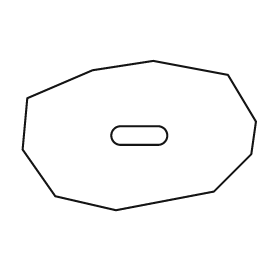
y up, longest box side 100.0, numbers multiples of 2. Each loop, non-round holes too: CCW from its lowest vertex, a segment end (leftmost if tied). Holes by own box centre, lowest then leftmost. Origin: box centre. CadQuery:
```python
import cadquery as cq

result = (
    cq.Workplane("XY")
    .moveTo(-10.0, -32.0)
    .lineTo(32.0, -24.0)
    .lineTo(48.0, -8.0)
    .lineTo(50.0, 6.0)
    .lineTo(38.0, 26.0)
    .lineTo(6.0, 32.0)
    .lineTo(-20.0, 28.0)
    .lineTo(-48.0, 16.0)
    .lineTo(-50.0, -6.0)
    .lineTo(-36.0, -26.0)
    .close()
    .moveTo(-8.0, -4.0)
    .lineTo(8.0, -4.0)
    .threePointArc((12.0, 0.0), (8.0, 4.0))
    .lineTo(-8.0, 4.0)
    .threePointArc((-12.0, 0.0), (-8.0, -4.0))
    .close()
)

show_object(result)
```